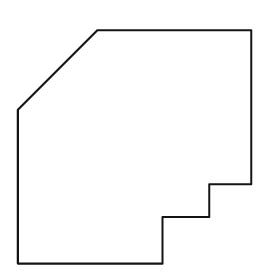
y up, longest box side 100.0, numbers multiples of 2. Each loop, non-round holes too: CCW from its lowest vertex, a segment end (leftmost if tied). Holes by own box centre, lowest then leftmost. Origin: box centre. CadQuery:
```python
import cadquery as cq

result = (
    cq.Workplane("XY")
    .moveTo(-50.0, -50.0)
    .lineTo(12.0, -50.0)
    .lineTo(12.0, -30.0)
    .lineTo(32.0, -30.0)
    .lineTo(32.0, -16.0)
    .lineTo(50.0, -16.0)
    .lineTo(50.0, 50.0)
    .lineTo(-16.0, 50.0)
    .lineTo(-50.0, 16.0)
    .close()
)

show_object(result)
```